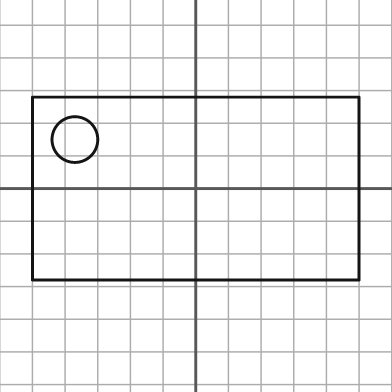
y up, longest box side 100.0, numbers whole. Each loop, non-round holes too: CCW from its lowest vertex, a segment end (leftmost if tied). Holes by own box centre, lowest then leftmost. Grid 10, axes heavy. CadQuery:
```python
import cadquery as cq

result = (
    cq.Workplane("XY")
    .moveTo(-50.0, -28.0)
    .lineTo(50.0, -28.0)
    .lineTo(50.0, 28.0)
    .lineTo(-50.0, 28.0)
    .close()
    .moveTo(-37.0, 15.0)
    .circle(7.0)
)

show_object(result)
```